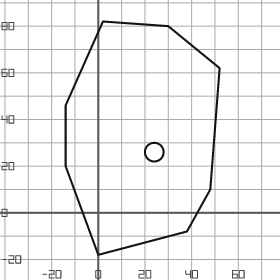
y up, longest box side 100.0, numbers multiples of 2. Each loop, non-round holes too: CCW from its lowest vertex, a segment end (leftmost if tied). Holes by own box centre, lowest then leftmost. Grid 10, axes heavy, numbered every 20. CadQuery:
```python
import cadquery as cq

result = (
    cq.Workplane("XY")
    .moveTo(0.0, -18.0)
    .lineTo(38.0, -8.0)
    .lineTo(48.0, 10.0)
    .lineTo(52.0, 62.0)
    .lineTo(30.0, 80.0)
    .lineTo(2.0, 82.0)
    .lineTo(-14.0, 46.0)
    .lineTo(-14.0, 20.0)
    .close()
    .moveTo(24.0, 26.0)
    .circle(4.0)
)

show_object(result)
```